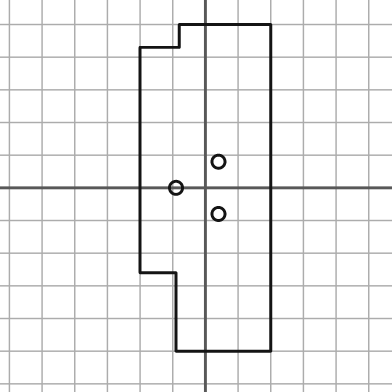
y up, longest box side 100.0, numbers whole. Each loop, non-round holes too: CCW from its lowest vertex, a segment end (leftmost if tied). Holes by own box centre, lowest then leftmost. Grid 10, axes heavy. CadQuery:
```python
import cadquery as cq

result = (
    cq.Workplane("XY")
    .moveTo(-9.0, -50.0)
    .lineTo(20.0, -50.0)
    .lineTo(20.0, 50.0)
    .lineTo(-8.0, 50.0)
    .lineTo(-8.0, 43.0)
    .lineTo(-20.0, 43.0)
    .lineTo(-20.0, -26.0)
    .lineTo(-9.0, -26.0)
    .close()
    .moveTo(4.0, -8.0)
    .circle(2.0)
    .moveTo(-9.0, 0.0)
    .circle(2.0)
    .moveTo(4.0, 8.0)
    .circle(2.0)
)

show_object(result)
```